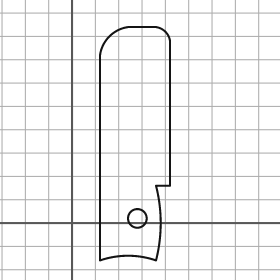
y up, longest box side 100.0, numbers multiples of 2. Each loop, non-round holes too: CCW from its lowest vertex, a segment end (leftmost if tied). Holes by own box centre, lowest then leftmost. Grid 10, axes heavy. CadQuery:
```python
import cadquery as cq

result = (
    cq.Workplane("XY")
    .moveTo(12.0, -16.0)
    .threePointArc((24.0, -14.0), (36.0, -16.0))
    .threePointArc((38.0, 0.0), (36.0, 16.0))
    .lineTo(42.0, 16.0)
    .lineTo(42.0, 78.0)
    .threePointArc((40.0, 82.0), (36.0, 84.0))
    .lineTo(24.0, 84.0)
    .threePointArc((16.0, 80.0), (12.0, 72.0))
    .close()
    .moveTo(28.0, 2.0)
    .circle(4.0)
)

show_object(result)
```